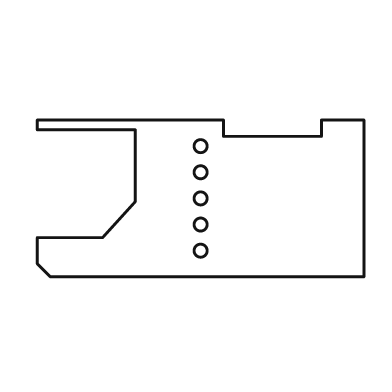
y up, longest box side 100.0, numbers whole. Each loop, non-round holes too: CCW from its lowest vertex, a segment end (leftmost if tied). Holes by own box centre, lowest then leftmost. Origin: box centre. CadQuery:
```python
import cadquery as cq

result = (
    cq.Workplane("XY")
    .moveTo(-46.0, -24.0)
    .lineTo(50.0, -24.0)
    .lineTo(50.0, 24.0)
    .lineTo(37.0, 24.0)
    .lineTo(37.0, 19.0)
    .lineTo(7.0, 19.0)
    .lineTo(7.0, 24.0)
    .lineTo(-50.0, 24.0)
    .lineTo(-50.0, 21.0)
    .lineTo(-20.0, 21.0)
    .lineTo(-20.0, -1.0)
    .lineTo(-30.0, -12.0)
    .lineTo(-50.0, -12.0)
    .lineTo(-50.0, -20.0)
    .close()
    .moveTo(0.0, -16.0)
    .circle(2.0)
    .moveTo(0.0, -8.0)
    .circle(2.0)
    .moveTo(0.0, 0.0)
    .circle(2.0)
    .moveTo(0.0, 8.0)
    .circle(2.0)
    .moveTo(0.0, 16.0)
    .circle(2.0)
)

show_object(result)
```